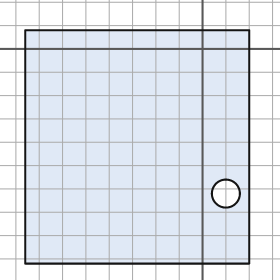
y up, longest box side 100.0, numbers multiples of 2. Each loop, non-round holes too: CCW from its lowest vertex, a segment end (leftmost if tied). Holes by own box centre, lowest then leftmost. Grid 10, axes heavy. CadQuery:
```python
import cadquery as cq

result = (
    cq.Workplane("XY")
    .moveTo(-76.0, -92.0)
    .lineTo(20.0, -92.0)
    .lineTo(20.0, 8.0)
    .lineTo(-76.0, 8.0)
    .close()
    .moveTo(10.0, -62.0)
    .circle(6.0)
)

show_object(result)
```